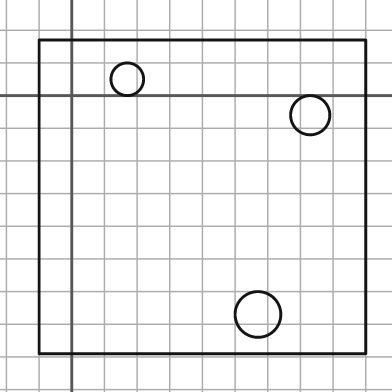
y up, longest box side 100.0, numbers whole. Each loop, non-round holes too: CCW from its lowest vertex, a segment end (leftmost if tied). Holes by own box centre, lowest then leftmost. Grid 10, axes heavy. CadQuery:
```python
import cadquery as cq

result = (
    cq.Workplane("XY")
    .moveTo(-10.0, -79.0)
    .lineTo(90.0, -79.0)
    .lineTo(90.0, 17.0)
    .lineTo(-10.0, 17.0)
    .close()
    .moveTo(57.0, -67.0)
    .circle(7.0)
    .moveTo(73.0, -6.0)
    .circle(6.0)
    .moveTo(17.0, 5.0)
    .circle(5.0)
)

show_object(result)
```